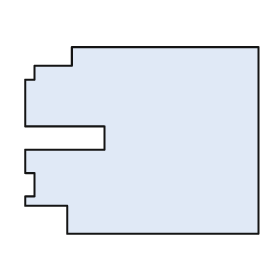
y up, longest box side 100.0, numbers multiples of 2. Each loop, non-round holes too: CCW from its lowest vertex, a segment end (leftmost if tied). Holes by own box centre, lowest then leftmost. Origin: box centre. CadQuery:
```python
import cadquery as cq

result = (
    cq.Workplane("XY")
    .moveTo(-32.0, -40.0)
    .lineTo(50.0, -40.0)
    .lineTo(50.0, 40.0)
    .lineTo(-30.0, 40.0)
    .lineTo(-30.0, 32.0)
    .lineTo(-46.0, 32.0)
    .lineTo(-46.0, 26.0)
    .lineTo(-50.0, 26.0)
    .lineTo(-50.0, 6.0)
    .lineTo(-16.0, 6.0)
    .lineTo(-16.0, -4.0)
    .lineTo(-50.0, -4.0)
    .lineTo(-50.0, -14.0)
    .lineTo(-46.0, -14.0)
    .lineTo(-46.0, -24.0)
    .lineTo(-50.0, -24.0)
    .lineTo(-50.0, -28.0)
    .lineTo(-32.0, -28.0)
    .close()
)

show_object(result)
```